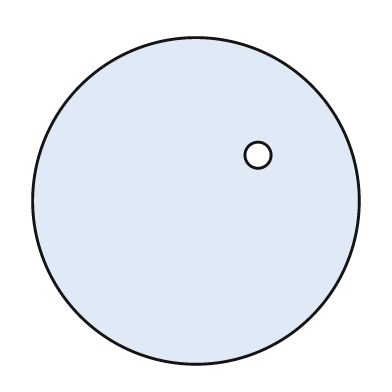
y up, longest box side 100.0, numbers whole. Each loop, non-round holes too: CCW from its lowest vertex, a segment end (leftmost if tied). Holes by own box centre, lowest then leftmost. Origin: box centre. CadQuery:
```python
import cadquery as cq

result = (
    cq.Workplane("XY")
    .moveTo(0.0, 0.0)
    .circle(50.0)
    .moveTo(19.0, 14.0)
    .circle(4.0)
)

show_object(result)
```